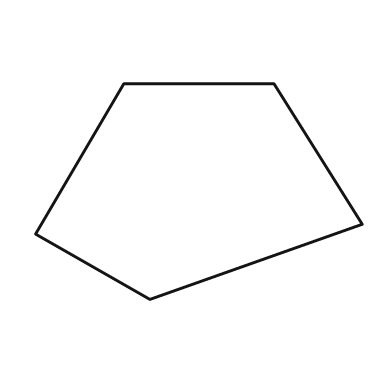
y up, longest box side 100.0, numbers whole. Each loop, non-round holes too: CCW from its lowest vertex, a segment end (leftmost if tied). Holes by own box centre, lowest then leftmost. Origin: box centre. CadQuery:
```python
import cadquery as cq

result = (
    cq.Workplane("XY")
    .moveTo(-15.0, -33.0)
    .lineTo(50.0, -10.0)
    .lineTo(23.0, 33.0)
    .lineTo(-23.0, 33.0)
    .lineTo(-50.0, -13.0)
    .close()
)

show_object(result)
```